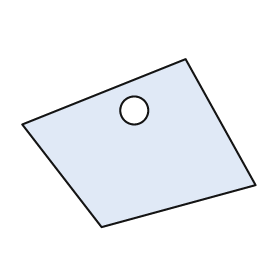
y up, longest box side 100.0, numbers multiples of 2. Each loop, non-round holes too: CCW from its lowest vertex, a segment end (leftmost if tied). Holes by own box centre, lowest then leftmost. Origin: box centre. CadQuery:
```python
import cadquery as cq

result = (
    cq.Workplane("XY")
    .moveTo(-16.0, -36.0)
    .lineTo(50.0, -18.0)
    .lineTo(20.0, 36.0)
    .lineTo(-50.0, 8.0)
    .close()
    .moveTo(-2.0, 14.0)
    .circle(6.0)
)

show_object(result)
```